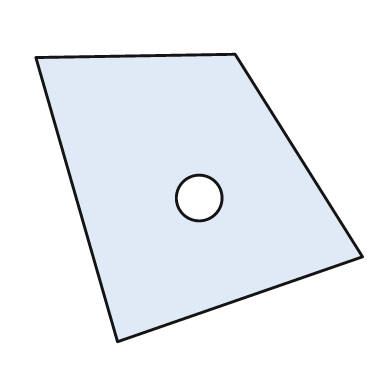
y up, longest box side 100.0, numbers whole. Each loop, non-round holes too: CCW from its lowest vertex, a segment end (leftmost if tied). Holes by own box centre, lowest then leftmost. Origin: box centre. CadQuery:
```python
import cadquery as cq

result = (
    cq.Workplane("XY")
    .moveTo(-25.0, -44.0)
    .lineTo(50.0, -18.0)
    .lineTo(11.0, 44.0)
    .lineTo(-50.0, 43.0)
    .close()
    .moveTo(0.0, 0.0)
    .circle(7.0)
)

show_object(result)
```